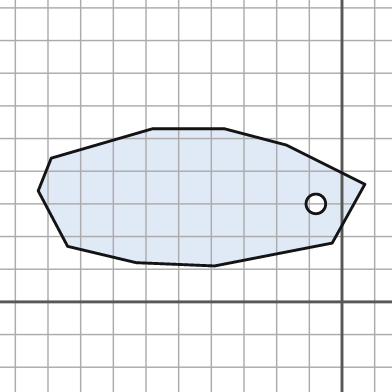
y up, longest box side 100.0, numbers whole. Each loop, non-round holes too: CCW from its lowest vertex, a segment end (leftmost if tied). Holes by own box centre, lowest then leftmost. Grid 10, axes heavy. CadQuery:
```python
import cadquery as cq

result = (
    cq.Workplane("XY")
    .moveTo(-39.0, 11.0)
    .lineTo(-3.0, 18.0)
    .lineTo(7.0, 36.0)
    .lineTo(-17.0, 48.0)
    .lineTo(-36.0, 53.0)
    .lineTo(-58.0, 53.0)
    .lineTo(-89.0, 44.0)
    .lineTo(-93.0, 34.0)
    .lineTo(-84.0, 17.0)
    .lineTo(-63.0, 12.0)
    .close()
    .moveTo(-8.0, 30.0)
    .circle(3.0)
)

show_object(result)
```